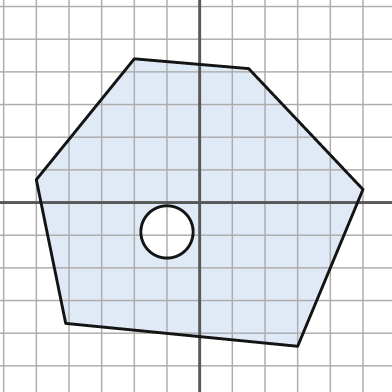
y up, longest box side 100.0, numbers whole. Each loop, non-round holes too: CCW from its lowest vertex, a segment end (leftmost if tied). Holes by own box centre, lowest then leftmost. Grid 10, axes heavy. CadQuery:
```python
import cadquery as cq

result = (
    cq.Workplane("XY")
    .moveTo(30.0, -44.0)
    .lineTo(50.0, 4.0)
    .lineTo(15.0, 41.0)
    .lineTo(-20.0, 44.0)
    .lineTo(-50.0, 7.0)
    .lineTo(-41.0, -37.0)
    .close()
    .moveTo(-10.0, -9.0)
    .circle(8.0)
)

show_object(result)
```